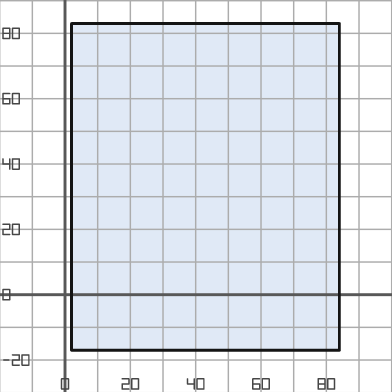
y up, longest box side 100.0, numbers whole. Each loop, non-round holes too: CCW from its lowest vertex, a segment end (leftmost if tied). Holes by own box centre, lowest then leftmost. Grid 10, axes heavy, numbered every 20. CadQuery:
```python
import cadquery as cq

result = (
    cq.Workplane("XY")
    .moveTo(2.0, -17.0)
    .lineTo(84.0, -17.0)
    .lineTo(84.0, 83.0)
    .lineTo(2.0, 83.0)
    .close()
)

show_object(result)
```